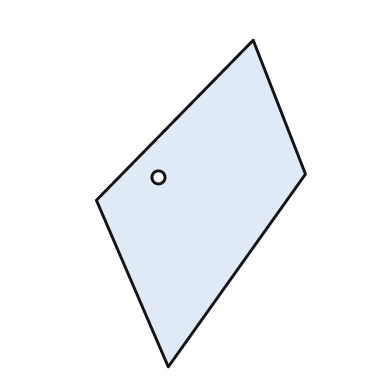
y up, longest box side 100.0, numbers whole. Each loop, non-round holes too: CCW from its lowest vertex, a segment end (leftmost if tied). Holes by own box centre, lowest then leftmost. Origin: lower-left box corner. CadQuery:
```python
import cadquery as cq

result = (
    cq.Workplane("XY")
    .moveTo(22.0, 0.0)
    .lineTo(64.0, 59.0)
    .lineTo(48.0, 100.0)
    .lineTo(0.0, 51.0)
    .close()
    .moveTo(19.0, 58.0)
    .circle(2.0)
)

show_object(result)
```